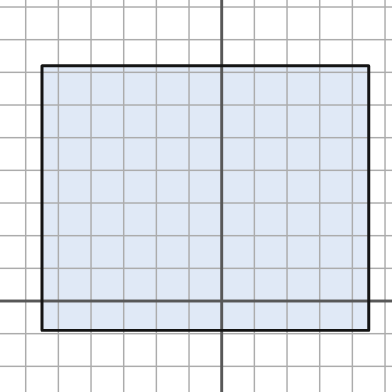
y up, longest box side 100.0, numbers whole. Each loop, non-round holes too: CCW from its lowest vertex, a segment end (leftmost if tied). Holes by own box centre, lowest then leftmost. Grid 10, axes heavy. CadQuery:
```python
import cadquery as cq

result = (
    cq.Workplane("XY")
    .moveTo(-55.0, -9.0)
    .lineTo(45.0, -9.0)
    .lineTo(45.0, 72.0)
    .lineTo(-55.0, 72.0)
    .close()
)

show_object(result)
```